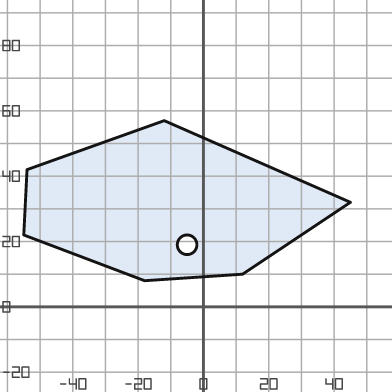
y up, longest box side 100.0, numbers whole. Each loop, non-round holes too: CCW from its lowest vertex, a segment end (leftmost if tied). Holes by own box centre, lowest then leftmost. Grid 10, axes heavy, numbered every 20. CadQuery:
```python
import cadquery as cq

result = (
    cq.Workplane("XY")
    .moveTo(-18.0, 8.0)
    .lineTo(12.0, 10.0)
    .lineTo(45.0, 32.0)
    .lineTo(-12.0, 57.0)
    .lineTo(-54.0, 42.0)
    .lineTo(-55.0, 22.0)
    .close()
    .moveTo(-5.0, 19.0)
    .circle(3.0)
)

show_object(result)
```